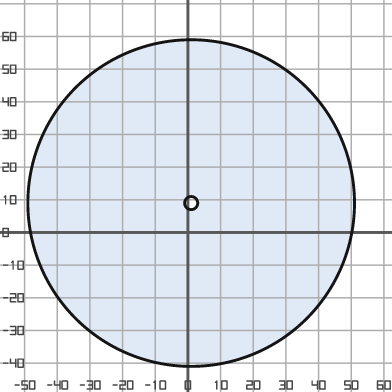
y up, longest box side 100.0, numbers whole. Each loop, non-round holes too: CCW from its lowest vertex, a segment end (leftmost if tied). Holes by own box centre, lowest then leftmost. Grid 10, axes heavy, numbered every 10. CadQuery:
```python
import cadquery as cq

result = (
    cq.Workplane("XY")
    .moveTo(1.0, 9.0)
    .circle(50.0)
    .moveTo(1.0, 9.0)
    .circle(2.0)
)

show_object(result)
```